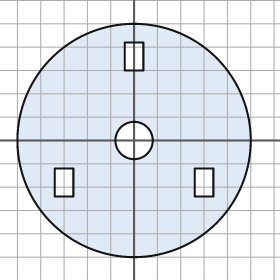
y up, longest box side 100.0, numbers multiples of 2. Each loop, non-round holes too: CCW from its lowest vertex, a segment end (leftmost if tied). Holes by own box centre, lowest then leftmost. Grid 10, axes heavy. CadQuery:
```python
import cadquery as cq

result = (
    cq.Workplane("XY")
    .moveTo(0.0, 0.0)
    .circle(50.0)
    .moveTo(-34.0, -24.0)
    .lineTo(-26.0, -24.0)
    .lineTo(-26.0, -12.0)
    .lineTo(-34.0, -12.0)
    .close()
    .moveTo(26.0, -24.0)
    .lineTo(34.0, -24.0)
    .lineTo(34.0, -12.0)
    .lineTo(26.0, -12.0)
    .close()
    .moveTo(0.0, 0.0)
    .circle(8.0)
    .moveTo(-4.0, 30.0)
    .lineTo(4.0, 30.0)
    .lineTo(4.0, 42.0)
    .lineTo(-4.0, 42.0)
    .close()
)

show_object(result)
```